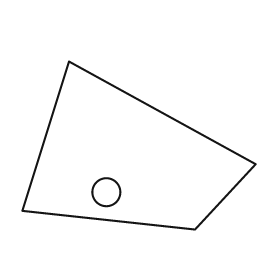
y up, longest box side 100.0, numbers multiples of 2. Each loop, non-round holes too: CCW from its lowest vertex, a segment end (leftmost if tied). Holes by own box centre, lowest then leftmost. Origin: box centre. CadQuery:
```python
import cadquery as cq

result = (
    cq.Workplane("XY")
    .moveTo(24.0, -36.0)
    .lineTo(50.0, -8.0)
    .lineTo(-30.0, 36.0)
    .lineTo(-50.0, -28.0)
    .close()
    .moveTo(-14.0, -20.0)
    .circle(6.0)
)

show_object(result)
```